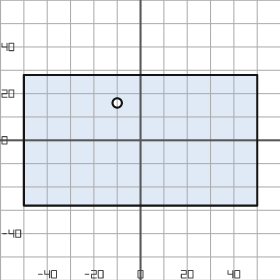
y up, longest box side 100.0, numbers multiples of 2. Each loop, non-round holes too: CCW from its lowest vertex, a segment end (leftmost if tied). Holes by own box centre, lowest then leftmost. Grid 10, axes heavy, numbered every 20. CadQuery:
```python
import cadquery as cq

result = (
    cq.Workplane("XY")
    .moveTo(-50.0, -28.0)
    .lineTo(50.0, -28.0)
    .lineTo(50.0, 28.0)
    .lineTo(-50.0, 28.0)
    .close()
    .moveTo(-10.0, 16.0)
    .circle(2.0)
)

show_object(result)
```